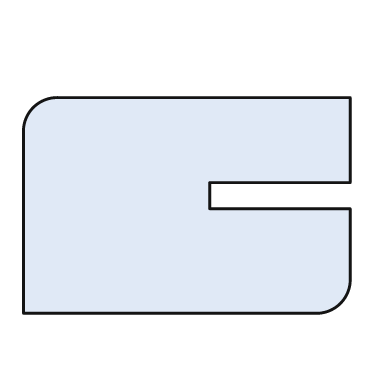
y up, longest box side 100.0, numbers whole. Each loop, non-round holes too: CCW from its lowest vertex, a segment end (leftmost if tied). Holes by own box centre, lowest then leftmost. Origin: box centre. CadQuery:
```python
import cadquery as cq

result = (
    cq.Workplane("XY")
    .moveTo(-50.0, -33.0)
    .lineTo(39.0, -33.0)
    .threePointArc((47.0, -30.0), (50.0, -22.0))
    .lineTo(50.0, -1.0)
    .lineTo(7.0, -1.0)
    .lineTo(7.0, 7.0)
    .lineTo(50.0, 7.0)
    .lineTo(50.0, 33.0)
    .lineTo(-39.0, 33.0)
    .threePointArc((-47.0, 30.0), (-50.0, 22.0))
    .close()
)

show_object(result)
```